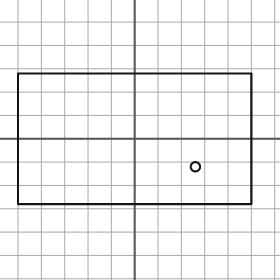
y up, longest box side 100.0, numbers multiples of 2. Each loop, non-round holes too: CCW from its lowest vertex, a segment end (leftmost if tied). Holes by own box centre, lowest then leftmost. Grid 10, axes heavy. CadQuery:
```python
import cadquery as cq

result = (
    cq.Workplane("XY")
    .moveTo(-50.0, -28.0)
    .lineTo(50.0, -28.0)
    .lineTo(50.0, 28.0)
    .lineTo(-50.0, 28.0)
    .close()
    .moveTo(26.0, -12.0)
    .circle(2.0)
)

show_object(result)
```